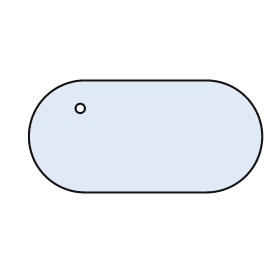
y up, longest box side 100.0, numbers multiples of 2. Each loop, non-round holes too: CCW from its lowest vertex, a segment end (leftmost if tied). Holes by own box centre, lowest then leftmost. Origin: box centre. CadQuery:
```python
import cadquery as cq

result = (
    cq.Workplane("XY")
    .moveTo(-26.0, -24.0)
    .lineTo(26.0, -24.0)
    .threePointArc((50.0, 0.0), (26.0, 24.0))
    .lineTo(-26.0, 24.0)
    .threePointArc((-50.0, 0.0), (-26.0, -24.0))
    .close()
    .moveTo(-28.0, 12.0)
    .circle(2.0)
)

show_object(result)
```